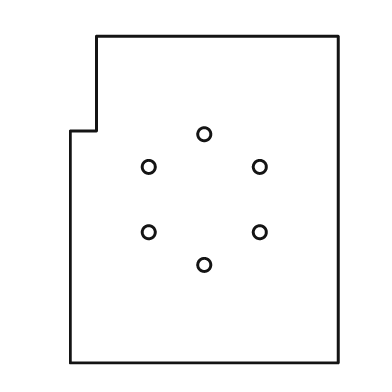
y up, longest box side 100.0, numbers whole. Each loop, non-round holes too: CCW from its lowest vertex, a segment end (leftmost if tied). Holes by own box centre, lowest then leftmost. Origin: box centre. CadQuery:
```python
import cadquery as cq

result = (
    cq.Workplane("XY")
    .moveTo(-41.0, -50.0)
    .lineTo(41.0, -50.0)
    .lineTo(41.0, 50.0)
    .lineTo(-33.0, 50.0)
    .lineTo(-33.0, 21.0)
    .lineTo(-41.0, 21.0)
    .close()
    .moveTo(0.0, -20.0)
    .circle(2.0)
    .moveTo(-17.0, -10.0)
    .circle(2.0)
    .moveTo(17.0, -10.0)
    .circle(2.0)
    .moveTo(-17.0, 10.0)
    .circle(2.0)
    .moveTo(17.0, 10.0)
    .circle(2.0)
    .moveTo(0.0, 20.0)
    .circle(2.0)
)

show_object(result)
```